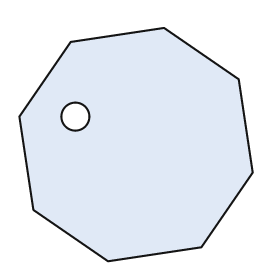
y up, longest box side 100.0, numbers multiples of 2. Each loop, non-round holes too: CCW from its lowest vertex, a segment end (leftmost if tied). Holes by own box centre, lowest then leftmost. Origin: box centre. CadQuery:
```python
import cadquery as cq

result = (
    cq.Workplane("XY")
    .moveTo(-12.0, -50.0)
    .lineTo(28.0, -44.0)
    .lineTo(50.0, -12.0)
    .lineTo(44.0, 28.0)
    .lineTo(12.0, 50.0)
    .lineTo(-28.0, 44.0)
    .lineTo(-50.0, 12.0)
    .lineTo(-44.0, -28.0)
    .close()
    .moveTo(-26.0, 12.0)
    .circle(6.0)
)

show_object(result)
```